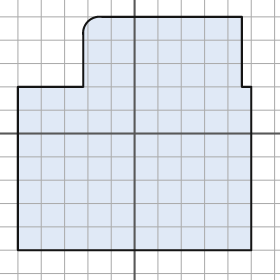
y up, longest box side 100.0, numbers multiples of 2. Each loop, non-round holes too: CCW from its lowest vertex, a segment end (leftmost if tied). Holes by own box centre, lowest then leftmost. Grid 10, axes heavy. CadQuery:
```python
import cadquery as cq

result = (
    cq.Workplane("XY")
    .moveTo(-50.0, -50.0)
    .lineTo(50.0, -50.0)
    .lineTo(50.0, 20.0)
    .lineTo(46.0, 20.0)
    .lineTo(46.0, 50.0)
    .lineTo(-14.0, 50.0)
    .threePointArc((-20.0, 48.0), (-22.0, 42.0))
    .lineTo(-22.0, 20.0)
    .lineTo(-50.0, 20.0)
    .close()
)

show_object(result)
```